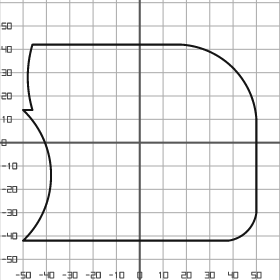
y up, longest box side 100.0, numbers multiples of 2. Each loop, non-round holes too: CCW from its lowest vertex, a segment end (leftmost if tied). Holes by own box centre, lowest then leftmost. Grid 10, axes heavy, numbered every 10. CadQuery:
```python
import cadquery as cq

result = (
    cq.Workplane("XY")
    .moveTo(-50.0, -42.0)
    .lineTo(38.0, -42.0)
    .threePointArc((46.0, -38.0), (50.0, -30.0))
    .lineTo(50.0, 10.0)
    .threePointArc((40.0, 32.0), (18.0, 42.0))
    .lineTo(-46.0, 42.0)
    .threePointArc((-48.0, 28.0), (-46.0, 14.0))
    .lineTo(-50.0, 14.0)
    .threePointArc((-38.0, -14.0), (-50.0, -42.0))
    .close()
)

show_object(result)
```